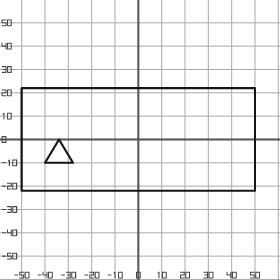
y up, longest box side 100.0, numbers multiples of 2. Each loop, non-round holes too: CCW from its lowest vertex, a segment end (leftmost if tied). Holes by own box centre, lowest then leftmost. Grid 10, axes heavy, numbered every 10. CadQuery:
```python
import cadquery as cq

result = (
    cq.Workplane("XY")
    .moveTo(-50.0, -22.0)
    .lineTo(50.0, -22.0)
    .lineTo(50.0, 22.0)
    .lineTo(-50.0, 22.0)
    .close()
    .moveTo(-40.0, -10.0)
    .lineTo(-28.0, -10.0)
    .lineTo(-34.0, 0.0)
    .close()
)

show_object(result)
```